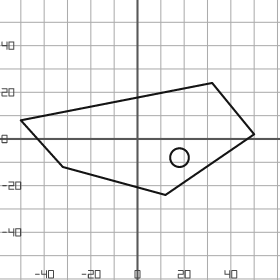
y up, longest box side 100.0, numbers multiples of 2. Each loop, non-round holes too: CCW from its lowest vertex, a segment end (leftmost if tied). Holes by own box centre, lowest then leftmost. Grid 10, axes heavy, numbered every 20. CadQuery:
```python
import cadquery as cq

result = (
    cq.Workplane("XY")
    .moveTo(12.0, -24.0)
    .lineTo(50.0, 2.0)
    .lineTo(32.0, 24.0)
    .lineTo(-50.0, 8.0)
    .lineTo(-32.0, -12.0)
    .close()
    .moveTo(18.0, -8.0)
    .circle(4.0)
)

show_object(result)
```